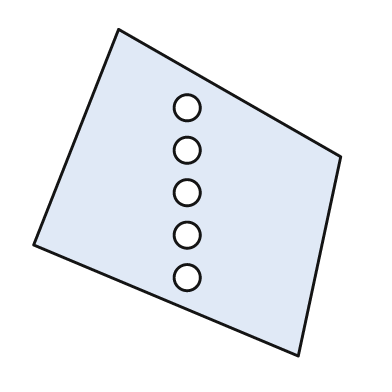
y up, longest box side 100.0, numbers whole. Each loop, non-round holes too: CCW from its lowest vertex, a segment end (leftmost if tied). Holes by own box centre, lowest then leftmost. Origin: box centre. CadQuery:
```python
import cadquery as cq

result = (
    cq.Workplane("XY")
    .moveTo(34.0, -50.0)
    .lineTo(47.0, 11.0)
    .lineTo(-21.0, 50.0)
    .lineTo(-47.0, -16.0)
    .close()
    .moveTo(0.0, -26.0)
    .circle(4.0)
    .moveTo(0.0, -13.0)
    .circle(4.0)
    .moveTo(0.0, 0.0)
    .circle(4.0)
    .moveTo(0.0, 13.0)
    .circle(4.0)
    .moveTo(0.0, 26.0)
    .circle(4.0)
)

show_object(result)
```